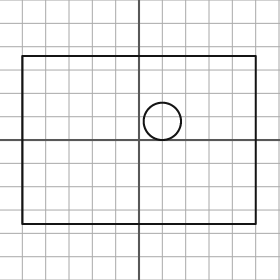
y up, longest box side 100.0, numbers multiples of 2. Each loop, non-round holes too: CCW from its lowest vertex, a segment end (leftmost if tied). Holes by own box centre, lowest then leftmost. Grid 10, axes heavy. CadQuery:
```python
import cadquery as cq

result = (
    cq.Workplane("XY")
    .moveTo(-50.0, -36.0)
    .lineTo(50.0, -36.0)
    .lineTo(50.0, 36.0)
    .lineTo(-50.0, 36.0)
    .close()
    .moveTo(10.0, 8.0)
    .circle(8.0)
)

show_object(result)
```